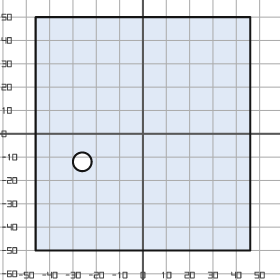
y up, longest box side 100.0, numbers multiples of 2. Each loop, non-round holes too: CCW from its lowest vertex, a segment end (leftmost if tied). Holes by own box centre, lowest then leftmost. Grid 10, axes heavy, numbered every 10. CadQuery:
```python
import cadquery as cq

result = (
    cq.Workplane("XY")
    .moveTo(-46.0, -50.0)
    .lineTo(46.0, -50.0)
    .lineTo(46.0, 50.0)
    .lineTo(-46.0, 50.0)
    .close()
    .moveTo(-26.0, -12.0)
    .circle(4.0)
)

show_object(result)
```